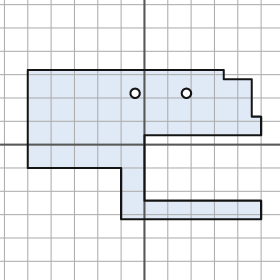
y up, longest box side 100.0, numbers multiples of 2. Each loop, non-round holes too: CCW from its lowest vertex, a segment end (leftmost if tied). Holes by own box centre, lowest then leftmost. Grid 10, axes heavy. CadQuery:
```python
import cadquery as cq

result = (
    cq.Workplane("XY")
    .moveTo(-10.0, -32.0)
    .lineTo(50.0, -32.0)
    .lineTo(50.0, -24.0)
    .lineTo(0.0, -24.0)
    .lineTo(0.0, 4.0)
    .lineTo(50.0, 4.0)
    .lineTo(50.0, 12.0)
    .lineTo(46.0, 12.0)
    .lineTo(46.0, 28.0)
    .lineTo(34.0, 28.0)
    .lineTo(34.0, 32.0)
    .lineTo(-50.0, 32.0)
    .lineTo(-50.0, -10.0)
    .lineTo(-10.0, -10.0)
    .close()
    .moveTo(-4.0, 22.0)
    .circle(2.0)
    .moveTo(18.0, 22.0)
    .circle(2.0)
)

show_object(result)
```